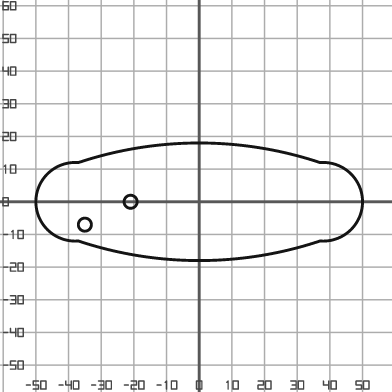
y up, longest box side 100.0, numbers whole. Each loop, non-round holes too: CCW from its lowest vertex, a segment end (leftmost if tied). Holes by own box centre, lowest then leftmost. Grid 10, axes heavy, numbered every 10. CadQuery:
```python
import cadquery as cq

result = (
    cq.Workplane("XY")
    .moveTo(-37.0, -12.0)
    .threePointArc((0.0, -18.0), (37.0, -12.0))
    .threePointArc((50.0, 0.0), (37.0, 12.0))
    .threePointArc((0.0, 18.0), (-37.0, 12.0))
    .threePointArc((-50.0, 0.0), (-37.0, -12.0))
    .close()
    .moveTo(-35.0, -7.0)
    .circle(2.0)
    .moveTo(-21.0, 0.0)
    .circle(2.0)
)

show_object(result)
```